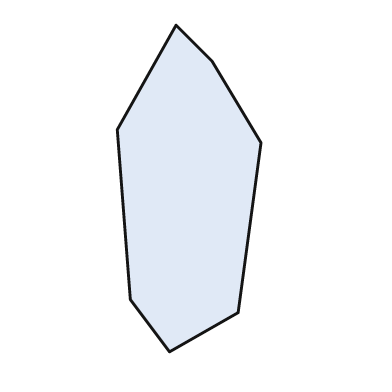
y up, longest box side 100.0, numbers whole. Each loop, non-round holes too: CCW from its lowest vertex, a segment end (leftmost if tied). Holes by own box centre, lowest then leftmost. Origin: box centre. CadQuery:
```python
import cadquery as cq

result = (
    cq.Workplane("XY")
    .moveTo(-6.0, -50.0)
    .lineTo(15.0, -38.0)
    .lineTo(22.0, 14.0)
    .lineTo(7.0, 39.0)
    .lineTo(-4.0, 50.0)
    .lineTo(-22.0, 18.0)
    .lineTo(-18.0, -34.0)
    .close()
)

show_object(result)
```